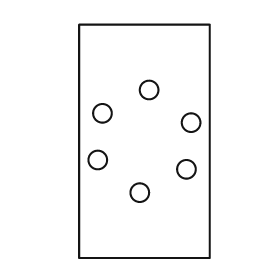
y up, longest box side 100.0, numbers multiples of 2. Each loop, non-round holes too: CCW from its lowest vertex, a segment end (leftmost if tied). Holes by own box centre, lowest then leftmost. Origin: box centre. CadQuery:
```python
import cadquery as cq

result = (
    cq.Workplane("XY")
    .moveTo(-28.0, -50.0)
    .lineTo(28.0, -50.0)
    .lineTo(28.0, 50.0)
    .lineTo(-28.0, 50.0)
    .close()
    .moveTo(-2.0, -22.0)
    .circle(4.0)
    .moveTo(18.0, -12.0)
    .circle(4.0)
    .moveTo(-20.0, -8.0)
    .circle(4.0)
    .moveTo(20.0, 8.0)
    .circle(4.0)
    .moveTo(-18.0, 12.0)
    .circle(4.0)
    .moveTo(2.0, 22.0)
    .circle(4.0)
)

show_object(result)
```